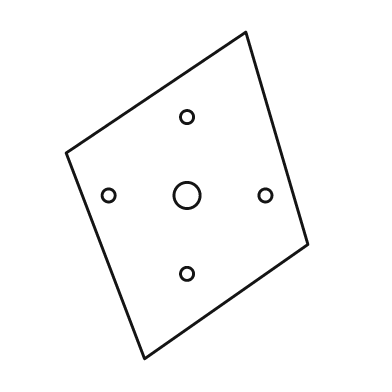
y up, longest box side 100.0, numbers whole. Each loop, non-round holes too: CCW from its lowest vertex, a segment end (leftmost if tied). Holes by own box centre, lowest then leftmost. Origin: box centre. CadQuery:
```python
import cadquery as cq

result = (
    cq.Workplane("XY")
    .moveTo(-13.0, -50.0)
    .lineTo(37.0, -15.0)
    .lineTo(18.0, 50.0)
    .lineTo(-37.0, 13.0)
    .close()
    .moveTo(0.0, -24.0)
    .circle(2.0)
    .moveTo(-24.0, 0.0)
    .circle(2.0)
    .moveTo(0.0, 0.0)
    .circle(4.0)
    .moveTo(24.0, 0.0)
    .circle(2.0)
    .moveTo(0.0, 24.0)
    .circle(2.0)
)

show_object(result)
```